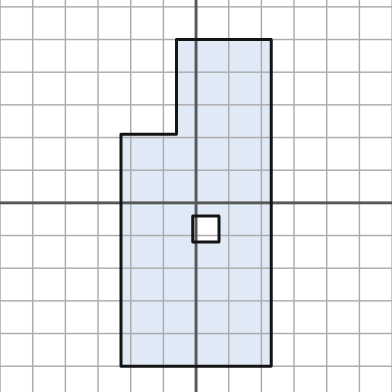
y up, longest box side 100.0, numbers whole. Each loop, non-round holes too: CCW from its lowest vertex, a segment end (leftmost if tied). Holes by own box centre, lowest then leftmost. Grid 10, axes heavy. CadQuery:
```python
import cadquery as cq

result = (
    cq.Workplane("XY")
    .moveTo(-23.0, -50.0)
    .lineTo(23.0, -50.0)
    .lineTo(23.0, 50.0)
    .lineTo(-6.0, 50.0)
    .lineTo(-6.0, 21.0)
    .lineTo(-23.0, 21.0)
    .close()
    .moveTo(-1.0, -12.0)
    .lineTo(7.0, -12.0)
    .lineTo(7.0, -4.0)
    .lineTo(-1.0, -4.0)
    .close()
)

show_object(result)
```